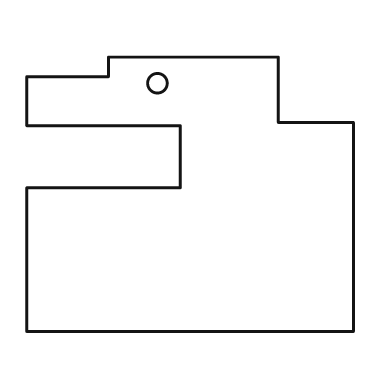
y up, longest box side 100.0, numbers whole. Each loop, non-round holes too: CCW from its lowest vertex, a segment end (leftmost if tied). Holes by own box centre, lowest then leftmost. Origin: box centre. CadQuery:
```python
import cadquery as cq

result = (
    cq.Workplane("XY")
    .moveTo(-50.0, -42.0)
    .lineTo(50.0, -42.0)
    .lineTo(50.0, 22.0)
    .lineTo(27.0, 22.0)
    .lineTo(27.0, 42.0)
    .lineTo(-25.0, 42.0)
    .lineTo(-25.0, 36.0)
    .lineTo(-50.0, 36.0)
    .lineTo(-50.0, 21.0)
    .lineTo(-3.0, 21.0)
    .lineTo(-3.0, 2.0)
    .lineTo(-50.0, 2.0)
    .close()
    .moveTo(-10.0, 34.0)
    .circle(3.0)
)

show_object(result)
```